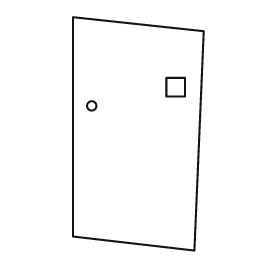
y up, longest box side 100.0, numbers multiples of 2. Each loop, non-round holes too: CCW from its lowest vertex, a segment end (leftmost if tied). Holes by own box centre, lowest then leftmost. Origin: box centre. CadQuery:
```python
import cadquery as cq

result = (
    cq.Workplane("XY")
    .moveTo(24.0, -50.0)
    .lineTo(28.0, 44.0)
    .lineTo(-28.0, 50.0)
    .lineTo(-28.0, -44.0)
    .close()
    .moveTo(-20.0, 12.0)
    .circle(2.0)
    .moveTo(12.0, 16.0)
    .lineTo(20.0, 16.0)
    .lineTo(20.0, 24.0)
    .lineTo(12.0, 24.0)
    .close()
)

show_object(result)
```